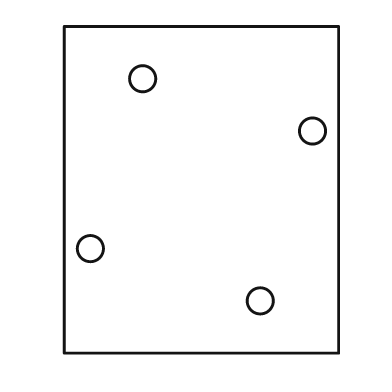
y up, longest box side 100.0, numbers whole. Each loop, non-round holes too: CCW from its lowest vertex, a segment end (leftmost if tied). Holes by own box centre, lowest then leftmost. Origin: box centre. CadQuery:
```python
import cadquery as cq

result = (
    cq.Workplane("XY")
    .moveTo(-42.0, -50.0)
    .lineTo(42.0, -50.0)
    .lineTo(42.0, 50.0)
    .lineTo(-42.0, 50.0)
    .close()
    .moveTo(18.0, -34.0)
    .circle(4.0)
    .moveTo(-34.0, -18.0)
    .circle(4.0)
    .moveTo(34.0, 18.0)
    .circle(4.0)
    .moveTo(-18.0, 34.0)
    .circle(4.0)
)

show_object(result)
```